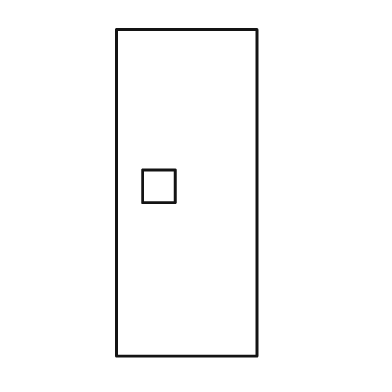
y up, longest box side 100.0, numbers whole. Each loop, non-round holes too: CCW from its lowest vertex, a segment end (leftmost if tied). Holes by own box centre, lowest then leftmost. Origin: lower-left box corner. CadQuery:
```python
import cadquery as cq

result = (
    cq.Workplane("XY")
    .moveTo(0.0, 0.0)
    .lineTo(43.0, 0.0)
    .lineTo(43.0, 100.0)
    .lineTo(0.0, 100.0)
    .close()
    .moveTo(8.0, 47.0)
    .lineTo(18.0, 47.0)
    .lineTo(18.0, 57.0)
    .lineTo(8.0, 57.0)
    .close()
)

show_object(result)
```